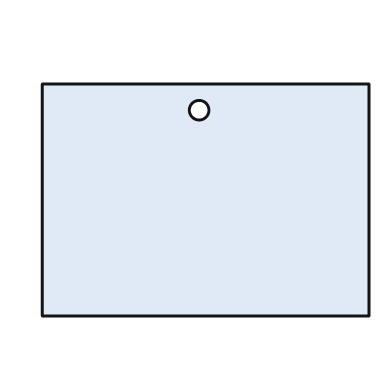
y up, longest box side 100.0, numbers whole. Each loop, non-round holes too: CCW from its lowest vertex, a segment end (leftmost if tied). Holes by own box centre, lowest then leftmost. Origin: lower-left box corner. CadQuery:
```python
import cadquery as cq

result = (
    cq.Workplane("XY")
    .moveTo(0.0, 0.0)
    .lineTo(100.0, 0.0)
    .lineTo(100.0, 71.0)
    .lineTo(0.0, 71.0)
    .close()
    .moveTo(48.0, 63.0)
    .circle(3.0)
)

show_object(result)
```